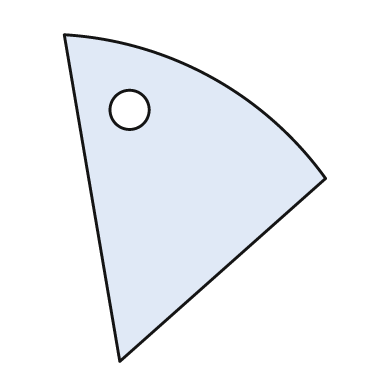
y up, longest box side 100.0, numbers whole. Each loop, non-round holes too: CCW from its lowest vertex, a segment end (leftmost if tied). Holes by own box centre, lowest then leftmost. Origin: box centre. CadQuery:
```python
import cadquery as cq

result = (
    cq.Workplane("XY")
    .moveTo(-23.0, -50.0)
    .lineTo(40.0, 6.0)
    .threePointArc((5.0, 37.0), (-40.0, 50.0))
    .close()
    .moveTo(-20.0, 27.0)
    .circle(6.0)
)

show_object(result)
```